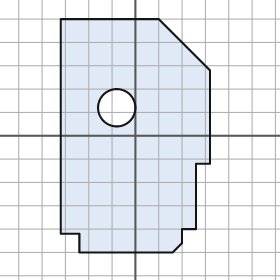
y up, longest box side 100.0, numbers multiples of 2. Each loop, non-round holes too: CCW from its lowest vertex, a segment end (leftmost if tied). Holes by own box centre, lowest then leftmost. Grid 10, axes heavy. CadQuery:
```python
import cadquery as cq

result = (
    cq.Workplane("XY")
    .moveTo(-24.0, -50.0)
    .lineTo(16.0, -50.0)
    .lineTo(20.0, -46.0)
    .lineTo(20.0, -40.0)
    .lineTo(26.0, -40.0)
    .lineTo(26.0, -12.0)
    .lineTo(32.0, -12.0)
    .lineTo(32.0, 28.0)
    .lineTo(10.0, 50.0)
    .lineTo(-32.0, 50.0)
    .lineTo(-32.0, -42.0)
    .lineTo(-24.0, -42.0)
    .close()
    .moveTo(-8.0, 12.0)
    .circle(8.0)
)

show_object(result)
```